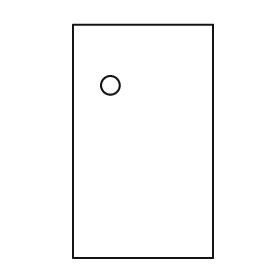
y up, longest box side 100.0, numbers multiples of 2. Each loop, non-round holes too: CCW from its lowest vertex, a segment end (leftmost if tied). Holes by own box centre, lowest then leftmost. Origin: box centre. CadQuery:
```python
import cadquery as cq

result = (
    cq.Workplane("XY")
    .moveTo(-30.0, -50.0)
    .lineTo(30.0, -50.0)
    .lineTo(30.0, 50.0)
    .lineTo(-30.0, 50.0)
    .close()
    .moveTo(-14.0, 24.0)
    .circle(4.0)
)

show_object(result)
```